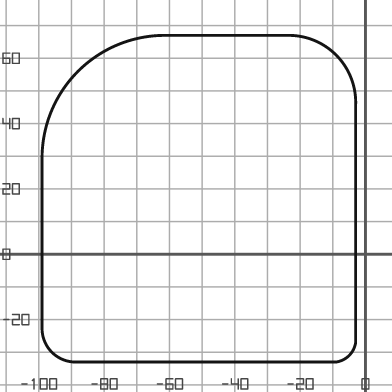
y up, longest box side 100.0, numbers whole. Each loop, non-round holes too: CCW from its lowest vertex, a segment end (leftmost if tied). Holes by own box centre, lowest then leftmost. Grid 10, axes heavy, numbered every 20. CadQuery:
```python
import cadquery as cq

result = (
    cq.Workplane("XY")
    .moveTo(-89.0, -33.0)
    .lineTo(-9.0, -33.0)
    .threePointArc((-5.0, -31.0), (-3.0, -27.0))
    .lineTo(-3.0, 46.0)
    .threePointArc((-9.0, 61.0), (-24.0, 67.0))
    .lineTo(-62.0, 67.0)
    .threePointArc((-88.0, 56.0), (-99.0, 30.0))
    .lineTo(-99.0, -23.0)
    .threePointArc((-96.0, -30.0), (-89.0, -33.0))
    .close()
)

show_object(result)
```